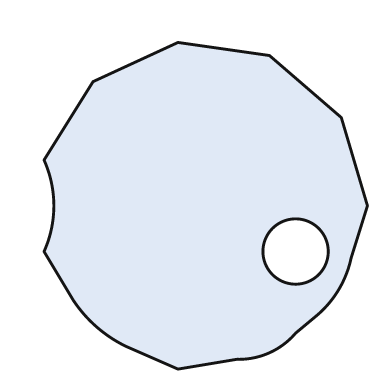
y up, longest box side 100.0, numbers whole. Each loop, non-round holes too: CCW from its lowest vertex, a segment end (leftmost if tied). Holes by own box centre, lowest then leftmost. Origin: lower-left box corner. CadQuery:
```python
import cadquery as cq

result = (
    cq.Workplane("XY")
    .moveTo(41.0, 0.0)
    .lineTo(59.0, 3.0)
    .threePointArc((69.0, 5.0), (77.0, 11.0))
    .lineTo(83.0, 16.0)
    .threePointArc((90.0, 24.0), (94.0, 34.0))
    .lineTo(99.0, 50.0)
    .lineTo(91.0, 77.0)
    .lineTo(69.0, 96.0)
    .lineTo(41.0, 100.0)
    .lineTo(15.0, 88.0)
    .lineTo(0.0, 64.0)
    .threePointArc((3.0, 50.0), (0.0, 36.0))
    .lineTo(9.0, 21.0)
    .threePointArc((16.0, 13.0), (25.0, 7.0))
    .close()
    .moveTo(77.0, 36.0)
    .circle(10.0)
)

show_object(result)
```